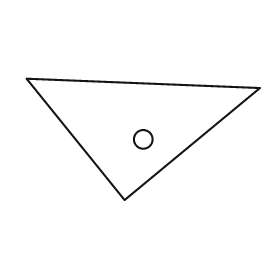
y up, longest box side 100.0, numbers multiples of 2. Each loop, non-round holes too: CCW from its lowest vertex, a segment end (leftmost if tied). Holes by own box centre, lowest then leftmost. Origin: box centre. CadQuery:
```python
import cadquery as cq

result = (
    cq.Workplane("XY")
    .moveTo(-8.0, -26.0)
    .lineTo(50.0, 22.0)
    .lineTo(-50.0, 26.0)
    .close()
    .moveTo(0.0, 0.0)
    .circle(4.0)
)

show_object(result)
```